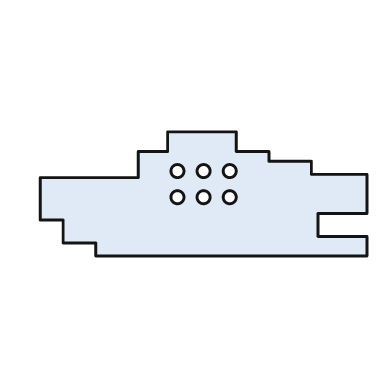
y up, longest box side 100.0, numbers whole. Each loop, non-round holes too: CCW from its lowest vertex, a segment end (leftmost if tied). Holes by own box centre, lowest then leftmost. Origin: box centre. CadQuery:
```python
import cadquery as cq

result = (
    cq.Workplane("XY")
    .moveTo(-33.0, -19.0)
    .lineTo(50.0, -19.0)
    .lineTo(50.0, -13.0)
    .lineTo(35.0, -13.0)
    .lineTo(35.0, -6.0)
    .lineTo(50.0, -6.0)
    .lineTo(50.0, 6.0)
    .lineTo(33.0, 6.0)
    .lineTo(33.0, 10.0)
    .lineTo(20.0, 10.0)
    .lineTo(20.0, 13.0)
    .lineTo(10.0, 13.0)
    .lineTo(10.0, 19.0)
    .lineTo(-11.0, 19.0)
    .lineTo(-11.0, 13.0)
    .lineTo(-20.0, 13.0)
    .lineTo(-20.0, 5.0)
    .lineTo(-50.0, 5.0)
    .lineTo(-50.0, -8.0)
    .lineTo(-43.0, -8.0)
    .lineTo(-43.0, -15.0)
    .lineTo(-33.0, -15.0)
    .close()
    .moveTo(-8.0, -1.0)
    .circle(2.0)
    .moveTo(0.0, -1.0)
    .circle(2.0)
    .moveTo(8.0, -1.0)
    .circle(2.0)
    .moveTo(-8.0, 7.0)
    .circle(2.0)
    .moveTo(0.0, 7.0)
    .circle(2.0)
    .moveTo(8.0, 7.0)
    .circle(2.0)
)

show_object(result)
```